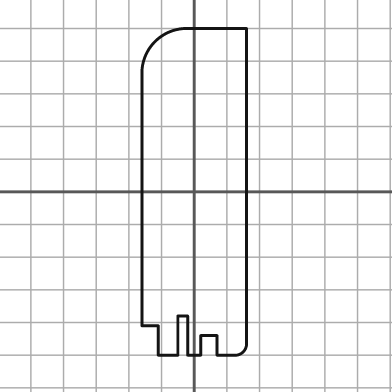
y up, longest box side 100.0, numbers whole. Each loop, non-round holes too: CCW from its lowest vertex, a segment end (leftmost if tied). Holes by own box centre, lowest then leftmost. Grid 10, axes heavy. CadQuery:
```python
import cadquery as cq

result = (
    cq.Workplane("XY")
    .moveTo(-11.0, -50.0)
    .lineTo(-5.0, -50.0)
    .lineTo(-5.0, -38.0)
    .lineTo(-2.0, -38.0)
    .lineTo(-2.0, -50.0)
    .lineTo(2.0, -50.0)
    .lineTo(2.0, -44.0)
    .lineTo(7.0, -44.0)
    .lineTo(7.0, -50.0)
    .lineTo(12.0, -50.0)
    .threePointArc((15.0, -49.0), (16.0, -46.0))
    .lineTo(16.0, 50.0)
    .lineTo(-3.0, 50.0)
    .threePointArc((-12.0, 46.0), (-16.0, 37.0))
    .lineTo(-16.0, -41.0)
    .lineTo(-11.0, -41.0)
    .close()
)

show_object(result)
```